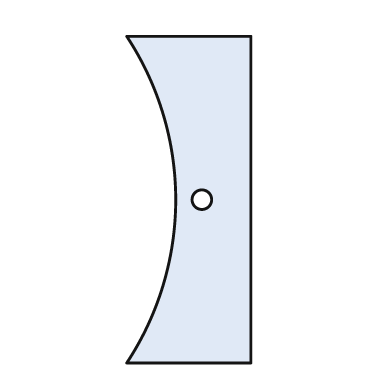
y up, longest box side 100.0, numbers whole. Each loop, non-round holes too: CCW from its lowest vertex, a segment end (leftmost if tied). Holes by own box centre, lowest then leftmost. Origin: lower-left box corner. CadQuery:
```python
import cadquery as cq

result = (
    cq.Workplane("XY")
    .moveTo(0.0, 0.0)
    .lineTo(38.0, 0.0)
    .lineTo(38.0, 100.0)
    .lineTo(0.0, 100.0)
    .threePointArc((15.0, 50.0), (0.0, 0.0))
    .close()
    .moveTo(23.0, 50.0)
    .circle(3.0)
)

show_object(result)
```